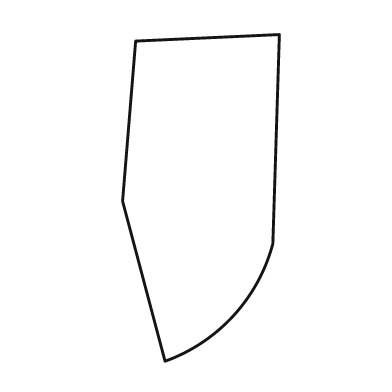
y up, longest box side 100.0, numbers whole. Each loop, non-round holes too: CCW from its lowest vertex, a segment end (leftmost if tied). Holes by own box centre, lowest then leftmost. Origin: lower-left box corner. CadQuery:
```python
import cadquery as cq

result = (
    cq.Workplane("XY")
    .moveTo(13.0, 0.0)
    .threePointArc((34.0, 14.0), (46.0, 36.0))
    .lineTo(48.0, 100.0)
    .lineTo(4.0, 98.0)
    .lineTo(0.0, 49.0)
    .close()
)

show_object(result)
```